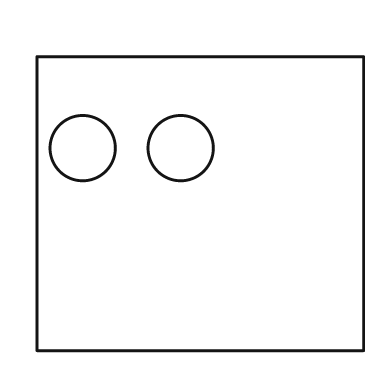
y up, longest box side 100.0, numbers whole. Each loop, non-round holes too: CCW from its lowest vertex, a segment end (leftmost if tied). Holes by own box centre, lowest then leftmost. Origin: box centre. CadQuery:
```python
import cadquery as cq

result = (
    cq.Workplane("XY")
    .moveTo(-50.0, -45.0)
    .lineTo(50.0, -45.0)
    .lineTo(50.0, 45.0)
    .lineTo(-50.0, 45.0)
    .close()
    .moveTo(-36.0, 17.0)
    .circle(10.0)
    .moveTo(-6.0, 17.0)
    .circle(10.0)
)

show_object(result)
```